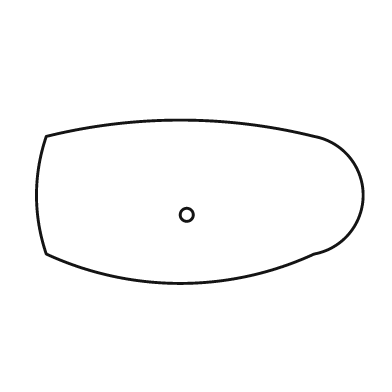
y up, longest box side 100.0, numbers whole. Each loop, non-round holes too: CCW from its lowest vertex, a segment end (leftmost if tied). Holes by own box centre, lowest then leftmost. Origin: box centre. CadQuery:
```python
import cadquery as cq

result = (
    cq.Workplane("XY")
    .moveTo(-47.0, -16.0)
    .threePointArc((-6.0, -25.0), (35.0, -16.0))
    .threePointArc((50.0, 2.0), (35.0, 20.0))
    .threePointArc((-6.0, 25.0), (-47.0, 20.0))
    .threePointArc((-50.0, 2.0), (-47.0, -16.0))
    .close()
    .moveTo(-4.0, -4.0)
    .circle(2.0)
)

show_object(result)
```